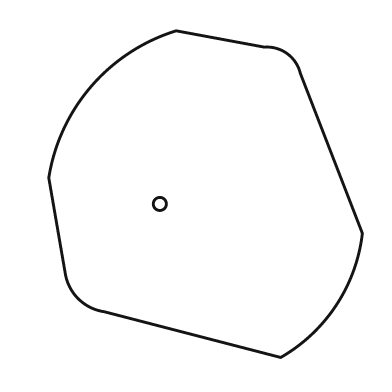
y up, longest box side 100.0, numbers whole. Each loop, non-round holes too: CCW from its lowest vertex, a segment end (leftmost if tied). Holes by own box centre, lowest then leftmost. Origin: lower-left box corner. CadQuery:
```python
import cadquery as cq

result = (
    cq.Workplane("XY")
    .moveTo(71.0, 0.0)
    .threePointArc((88.0, 16.0), (96.0, 38.0))
    .lineTo(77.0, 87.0)
    .threePointArc((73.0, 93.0), (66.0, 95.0))
    .lineTo(39.0, 100.0)
    .threePointArc((13.0, 83.0), (0.0, 55.0))
    .lineTo(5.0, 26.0)
    .threePointArc((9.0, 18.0), (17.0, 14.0))
    .close()
    .moveTo(34.0, 47.0)
    .circle(2.0)
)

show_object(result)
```